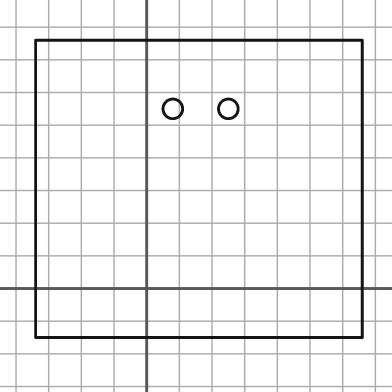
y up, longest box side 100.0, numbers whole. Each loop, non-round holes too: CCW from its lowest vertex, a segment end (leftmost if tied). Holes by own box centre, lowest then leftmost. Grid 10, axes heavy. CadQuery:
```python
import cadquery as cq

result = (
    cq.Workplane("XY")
    .moveTo(-34.0, -15.0)
    .lineTo(66.0, -15.0)
    .lineTo(66.0, 76.0)
    .lineTo(-34.0, 76.0)
    .close()
    .moveTo(8.0, 55.0)
    .circle(3.0)
    .moveTo(25.0, 55.0)
    .circle(3.0)
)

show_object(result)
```